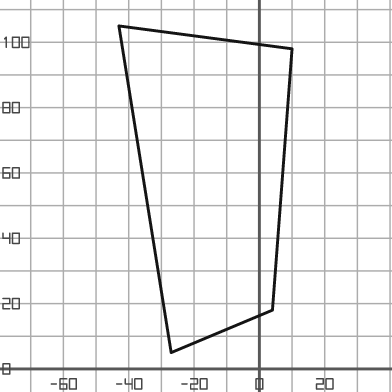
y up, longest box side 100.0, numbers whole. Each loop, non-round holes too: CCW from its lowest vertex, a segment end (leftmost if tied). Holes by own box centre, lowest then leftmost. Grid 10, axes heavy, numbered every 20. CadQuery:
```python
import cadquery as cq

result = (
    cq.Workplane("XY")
    .moveTo(-27.0, 5.0)
    .lineTo(4.0, 18.0)
    .lineTo(10.0, 98.0)
    .lineTo(-43.0, 105.0)
    .close()
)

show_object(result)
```